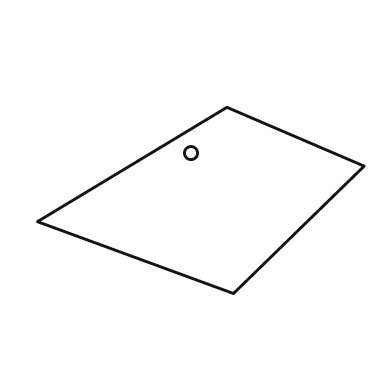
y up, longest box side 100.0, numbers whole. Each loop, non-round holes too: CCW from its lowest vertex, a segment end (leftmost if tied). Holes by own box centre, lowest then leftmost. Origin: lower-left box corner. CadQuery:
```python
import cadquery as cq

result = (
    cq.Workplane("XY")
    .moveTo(60.0, 0.0)
    .lineTo(100.0, 39.0)
    .lineTo(58.0, 57.0)
    .lineTo(0.0, 22.0)
    .close()
    .moveTo(47.0, 43.0)
    .circle(2.0)
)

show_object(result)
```